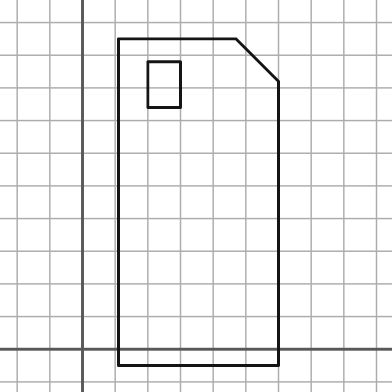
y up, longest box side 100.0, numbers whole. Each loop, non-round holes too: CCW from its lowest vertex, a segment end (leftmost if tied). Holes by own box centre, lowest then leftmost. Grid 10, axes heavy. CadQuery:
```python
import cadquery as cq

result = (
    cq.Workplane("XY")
    .moveTo(11.0, -5.0)
    .lineTo(60.0, -5.0)
    .lineTo(60.0, 82.0)
    .lineTo(47.0, 95.0)
    .lineTo(11.0, 95.0)
    .close()
    .moveTo(20.0, 74.0)
    .lineTo(30.0, 74.0)
    .lineTo(30.0, 88.0)
    .lineTo(20.0, 88.0)
    .close()
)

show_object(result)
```